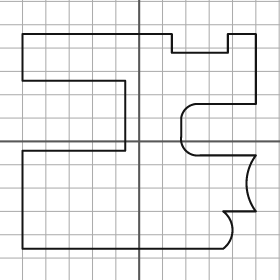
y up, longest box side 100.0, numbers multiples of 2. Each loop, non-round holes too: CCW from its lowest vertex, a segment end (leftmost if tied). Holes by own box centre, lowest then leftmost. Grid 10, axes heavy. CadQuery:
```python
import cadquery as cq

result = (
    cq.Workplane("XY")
    .moveTo(-50.0, -46.0)
    .lineTo(36.0, -46.0)
    .threePointArc((40.0, -38.0), (36.0, -30.0))
    .lineTo(50.0, -30.0)
    .threePointArc((46.0, -18.0), (50.0, -6.0))
    .lineTo(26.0, -6.0)
    .threePointArc((20.0, -4.0), (18.0, 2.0))
    .lineTo(18.0, 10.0)
    .threePointArc((20.0, 14.0), (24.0, 16.0))
    .lineTo(50.0, 16.0)
    .lineTo(50.0, 46.0)
    .lineTo(38.0, 46.0)
    .lineTo(38.0, 38.0)
    .lineTo(14.0, 38.0)
    .lineTo(14.0, 46.0)
    .lineTo(-50.0, 46.0)
    .lineTo(-50.0, 26.0)
    .lineTo(-6.0, 26.0)
    .lineTo(-6.0, -4.0)
    .lineTo(-50.0, -4.0)
    .close()
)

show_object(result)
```